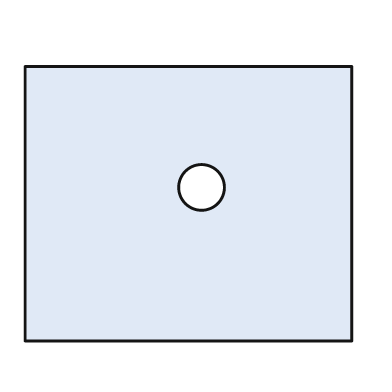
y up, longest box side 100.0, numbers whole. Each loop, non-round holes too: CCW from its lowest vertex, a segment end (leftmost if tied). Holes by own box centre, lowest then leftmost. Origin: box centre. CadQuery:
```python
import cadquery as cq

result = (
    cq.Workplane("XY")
    .moveTo(-50.0, -42.0)
    .lineTo(50.0, -42.0)
    .lineTo(50.0, 42.0)
    .lineTo(-50.0, 42.0)
    .close()
    .moveTo(4.0, 5.0)
    .circle(7.0)
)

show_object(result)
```